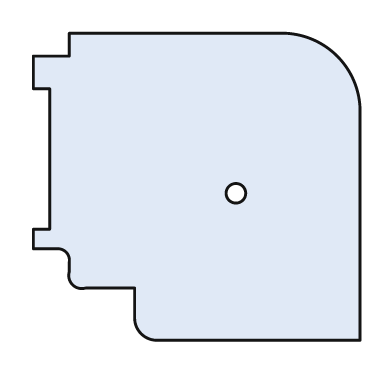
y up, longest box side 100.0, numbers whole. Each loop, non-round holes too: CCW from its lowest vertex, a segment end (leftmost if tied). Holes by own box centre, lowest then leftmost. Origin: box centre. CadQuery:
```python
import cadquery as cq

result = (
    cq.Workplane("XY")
    .moveTo(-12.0, -47.0)
    .lineTo(50.0, -47.0)
    .lineTo(50.0, 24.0)
    .threePointArc((43.0, 40.0), (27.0, 47.0))
    .lineTo(-39.0, 47.0)
    .lineTo(-39.0, 40.0)
    .lineTo(-50.0, 40.0)
    .lineTo(-50.0, 30.0)
    .lineTo(-45.0, 30.0)
    .lineTo(-45.0, -13.0)
    .lineTo(-50.0, -13.0)
    .lineTo(-50.0, -19.0)
    .lineTo(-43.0, -19.0)
    .threePointArc((-40.0, -20.0), (-39.0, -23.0))
    .lineTo(-39.0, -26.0)
    .threePointArc((-38.0, -30.0), (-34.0, -31.0))
    .lineTo(-19.0, -31.0)
    .lineTo(-19.0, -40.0)
    .threePointArc((-17.0, -45.0), (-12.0, -47.0))
    .close()
    .moveTo(12.0, -2.0)
    .circle(3.0)
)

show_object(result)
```